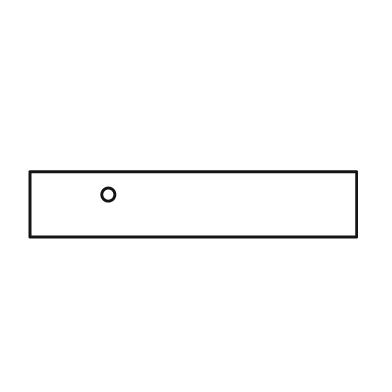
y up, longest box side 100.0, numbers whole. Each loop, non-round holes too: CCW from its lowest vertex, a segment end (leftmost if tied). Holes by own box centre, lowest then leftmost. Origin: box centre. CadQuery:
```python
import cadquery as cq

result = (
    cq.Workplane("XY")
    .moveTo(-50.0, -10.0)
    .lineTo(50.0, -10.0)
    .lineTo(50.0, 10.0)
    .lineTo(-50.0, 10.0)
    .close()
    .moveTo(-26.0, 3.0)
    .circle(2.0)
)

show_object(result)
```